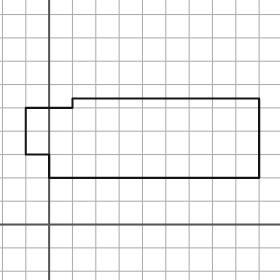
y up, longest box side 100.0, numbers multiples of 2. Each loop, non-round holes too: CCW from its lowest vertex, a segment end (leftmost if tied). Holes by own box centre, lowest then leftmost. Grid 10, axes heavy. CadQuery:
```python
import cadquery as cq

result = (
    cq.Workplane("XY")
    .moveTo(0.0, 20.0)
    .lineTo(90.0, 20.0)
    .lineTo(90.0, 54.0)
    .lineTo(10.0, 54.0)
    .lineTo(10.0, 50.0)
    .lineTo(-10.0, 50.0)
    .lineTo(-10.0, 30.0)
    .lineTo(0.0, 30.0)
    .close()
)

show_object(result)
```